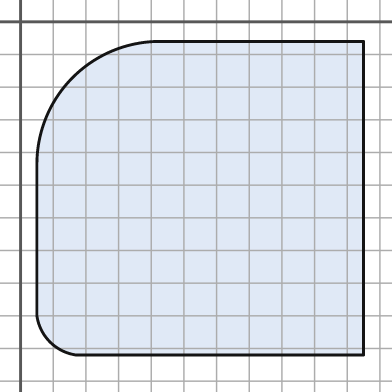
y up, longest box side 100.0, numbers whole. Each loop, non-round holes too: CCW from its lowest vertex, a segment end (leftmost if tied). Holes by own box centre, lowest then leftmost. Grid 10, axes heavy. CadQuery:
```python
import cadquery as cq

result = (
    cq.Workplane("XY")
    .moveTo(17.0, -102.0)
    .lineTo(105.0, -102.0)
    .lineTo(105.0, -6.0)
    .lineTo(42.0, -6.0)
    .threePointArc((16.0, -17.0), (5.0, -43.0))
    .lineTo(5.0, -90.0)
    .threePointArc((9.0, -98.0), (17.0, -102.0))
    .close()
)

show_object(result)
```